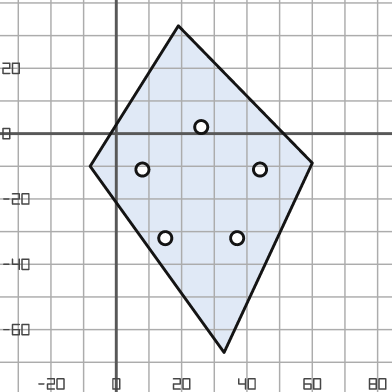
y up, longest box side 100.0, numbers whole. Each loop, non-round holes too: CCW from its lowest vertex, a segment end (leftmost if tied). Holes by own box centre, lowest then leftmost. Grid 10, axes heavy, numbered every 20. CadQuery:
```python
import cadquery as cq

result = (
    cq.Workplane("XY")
    .moveTo(33.0, -67.0)
    .lineTo(60.0, -9.0)
    .lineTo(19.0, 33.0)
    .lineTo(-8.0, -10.0)
    .close()
    .moveTo(15.0, -32.0)
    .circle(2.0)
    .moveTo(37.0, -32.0)
    .circle(2.0)
    .moveTo(8.0, -11.0)
    .circle(2.0)
    .moveTo(44.0, -11.0)
    .circle(2.0)
    .moveTo(26.0, 2.0)
    .circle(2.0)
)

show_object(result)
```